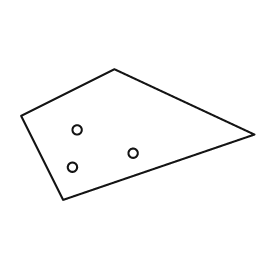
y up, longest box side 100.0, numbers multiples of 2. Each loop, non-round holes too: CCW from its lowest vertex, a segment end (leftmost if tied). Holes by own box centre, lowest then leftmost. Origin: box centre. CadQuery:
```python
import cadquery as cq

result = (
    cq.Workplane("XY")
    .moveTo(-32.0, -28.0)
    .lineTo(50.0, 0.0)
    .lineTo(-10.0, 28.0)
    .lineTo(-50.0, 8.0)
    .close()
    .moveTo(-28.0, -14.0)
    .circle(2.0)
    .moveTo(-2.0, -8.0)
    .circle(2.0)
    .moveTo(-26.0, 2.0)
    .circle(2.0)
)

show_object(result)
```